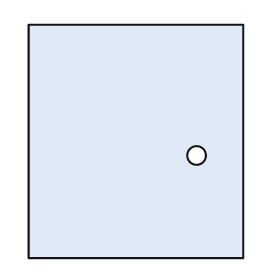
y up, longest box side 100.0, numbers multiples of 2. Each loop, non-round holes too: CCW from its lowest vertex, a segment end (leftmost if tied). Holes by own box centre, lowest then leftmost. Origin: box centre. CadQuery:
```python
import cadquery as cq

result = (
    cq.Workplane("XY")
    .moveTo(-46.0, -50.0)
    .lineTo(46.0, -50.0)
    .lineTo(46.0, 50.0)
    .lineTo(-46.0, 50.0)
    .close()
    .moveTo(26.0, -6.0)
    .circle(4.0)
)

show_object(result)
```